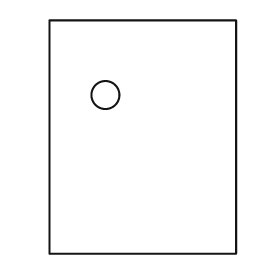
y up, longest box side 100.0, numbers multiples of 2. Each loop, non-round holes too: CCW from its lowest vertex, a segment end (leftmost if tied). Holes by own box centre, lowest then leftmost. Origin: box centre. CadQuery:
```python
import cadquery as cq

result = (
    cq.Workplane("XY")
    .moveTo(-40.0, -50.0)
    .lineTo(40.0, -50.0)
    .lineTo(40.0, 50.0)
    .lineTo(-40.0, 50.0)
    .close()
    .moveTo(-16.0, 18.0)
    .circle(6.0)
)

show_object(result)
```